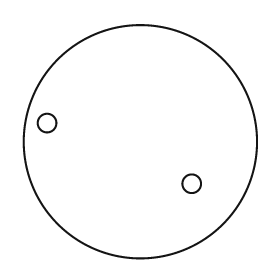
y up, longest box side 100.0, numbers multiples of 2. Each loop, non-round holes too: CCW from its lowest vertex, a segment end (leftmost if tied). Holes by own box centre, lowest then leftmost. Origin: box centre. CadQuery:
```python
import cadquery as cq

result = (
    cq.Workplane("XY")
    .moveTo(0.0, 0.0)
    .circle(50.0)
    .moveTo(22.0, -18.0)
    .circle(4.0)
    .moveTo(-40.0, 8.0)
    .circle(4.0)
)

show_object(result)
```